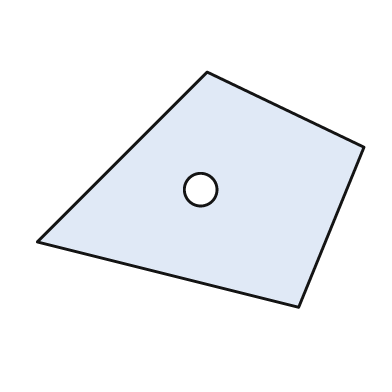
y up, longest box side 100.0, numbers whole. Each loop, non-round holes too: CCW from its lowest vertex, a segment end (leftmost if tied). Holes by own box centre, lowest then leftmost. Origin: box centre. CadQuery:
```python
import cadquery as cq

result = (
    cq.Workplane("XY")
    .moveTo(30.0, -36.0)
    .lineTo(50.0, 13.0)
    .lineTo(2.0, 36.0)
    .lineTo(-50.0, -16.0)
    .close()
    .moveTo(0.0, 0.0)
    .circle(5.0)
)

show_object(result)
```